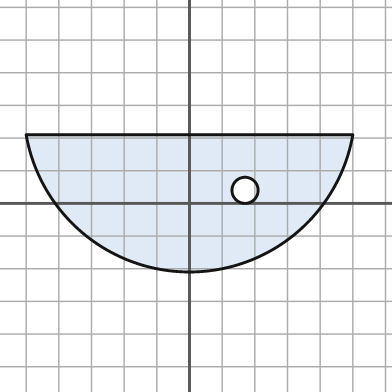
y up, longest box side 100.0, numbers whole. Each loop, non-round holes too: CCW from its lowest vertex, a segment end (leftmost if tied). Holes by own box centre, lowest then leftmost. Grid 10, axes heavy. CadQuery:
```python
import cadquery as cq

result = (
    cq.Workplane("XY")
    .moveTo(-50.0, 21.0)
    .threePointArc((0.0, -21.0), (50.0, 21.0))
    .close()
    .moveTo(17.0, 4.0)
    .circle(4.0)
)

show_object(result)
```